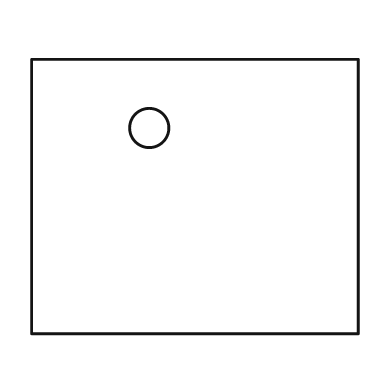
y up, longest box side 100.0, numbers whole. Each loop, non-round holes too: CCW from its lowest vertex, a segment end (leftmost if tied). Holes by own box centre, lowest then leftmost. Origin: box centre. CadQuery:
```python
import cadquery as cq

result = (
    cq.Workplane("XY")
    .moveTo(-50.0, -42.0)
    .lineTo(50.0, -42.0)
    .lineTo(50.0, 42.0)
    .lineTo(-50.0, 42.0)
    .close()
    .moveTo(-14.0, 21.0)
    .circle(6.0)
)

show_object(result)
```